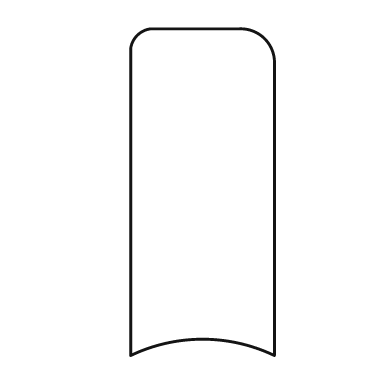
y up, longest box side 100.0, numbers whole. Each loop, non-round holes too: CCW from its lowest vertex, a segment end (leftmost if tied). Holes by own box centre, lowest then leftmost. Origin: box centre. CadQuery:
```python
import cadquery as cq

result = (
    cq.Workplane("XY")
    .moveTo(-22.0, -50.0)
    .threePointArc((0.0, -45.0), (22.0, -50.0))
    .lineTo(22.0, 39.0)
    .threePointArc((19.0, 47.0), (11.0, 50.0))
    .lineTo(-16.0, 50.0)
    .threePointArc((-20.0, 48.0), (-22.0, 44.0))
    .close()
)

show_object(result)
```